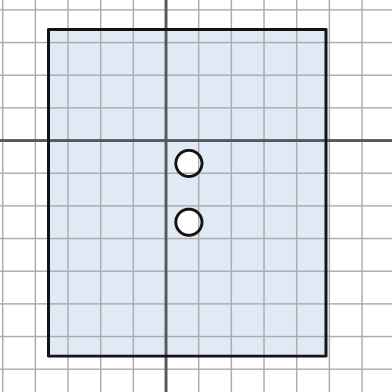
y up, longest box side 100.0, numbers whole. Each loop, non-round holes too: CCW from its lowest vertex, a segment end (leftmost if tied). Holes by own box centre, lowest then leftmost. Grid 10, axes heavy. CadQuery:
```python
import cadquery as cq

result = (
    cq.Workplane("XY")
    .moveTo(-36.0, -66.0)
    .lineTo(49.0, -66.0)
    .lineTo(49.0, 34.0)
    .lineTo(-36.0, 34.0)
    .close()
    .moveTo(7.0, -25.0)
    .circle(4.0)
    .moveTo(7.0, -7.0)
    .circle(4.0)
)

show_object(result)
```